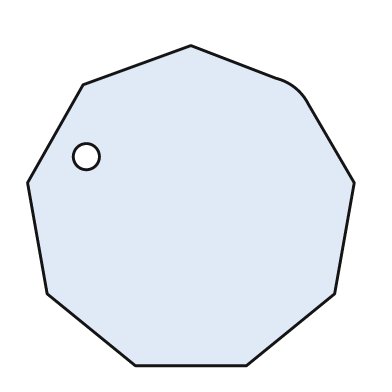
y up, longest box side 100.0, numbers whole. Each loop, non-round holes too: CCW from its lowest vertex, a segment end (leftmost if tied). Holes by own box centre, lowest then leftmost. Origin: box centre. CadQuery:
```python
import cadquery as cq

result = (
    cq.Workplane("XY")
    .moveTo(-17.0, -49.0)
    .lineTo(17.0, -49.0)
    .lineTo(44.0, -27.0)
    .lineTo(50.0, 7.0)
    .lineTo(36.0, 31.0)
    .threePointArc((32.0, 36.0), (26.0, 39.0))
    .lineTo(0.0, 49.0)
    .lineTo(-33.0, 37.0)
    .lineTo(-50.0, 7.0)
    .lineTo(-44.0, -27.0)
    .close()
    .moveTo(-32.0, 15.0)
    .circle(4.0)
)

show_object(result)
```